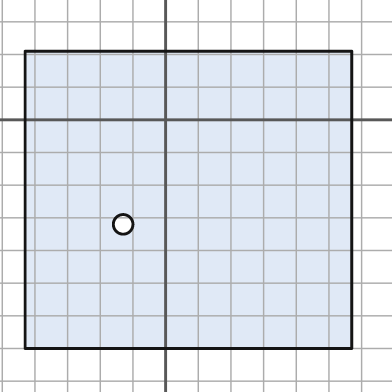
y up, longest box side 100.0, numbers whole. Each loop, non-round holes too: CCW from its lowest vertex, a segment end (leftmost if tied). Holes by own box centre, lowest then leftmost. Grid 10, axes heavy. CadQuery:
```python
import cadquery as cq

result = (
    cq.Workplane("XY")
    .moveTo(-43.0, -70.0)
    .lineTo(57.0, -70.0)
    .lineTo(57.0, 21.0)
    .lineTo(-43.0, 21.0)
    .close()
    .moveTo(-13.0, -32.0)
    .circle(3.0)
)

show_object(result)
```